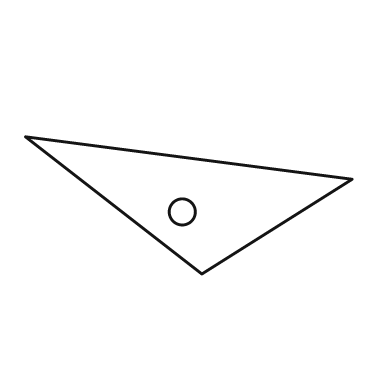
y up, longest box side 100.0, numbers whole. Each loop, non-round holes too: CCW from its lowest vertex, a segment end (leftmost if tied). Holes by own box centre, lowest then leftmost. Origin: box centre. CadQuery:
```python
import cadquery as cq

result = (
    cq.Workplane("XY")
    .moveTo(4.0, -21.0)
    .lineTo(50.0, 8.0)
    .lineTo(-50.0, 21.0)
    .close()
    .moveTo(-2.0, -2.0)
    .circle(4.0)
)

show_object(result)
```